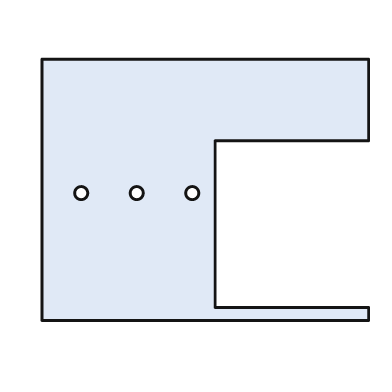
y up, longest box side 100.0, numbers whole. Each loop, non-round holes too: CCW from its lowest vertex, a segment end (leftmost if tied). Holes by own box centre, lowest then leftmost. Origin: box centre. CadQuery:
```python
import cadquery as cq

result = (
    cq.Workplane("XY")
    .moveTo(-50.0, -40.0)
    .lineTo(50.0, -40.0)
    .lineTo(50.0, -36.0)
    .lineTo(3.0, -36.0)
    .lineTo(3.0, 15.0)
    .lineTo(50.0, 15.0)
    .lineTo(50.0, 40.0)
    .lineTo(-50.0, 40.0)
    .close()
    .moveTo(-38.0, -1.0)
    .circle(2.0)
    .moveTo(-21.0, -1.0)
    .circle(2.0)
    .moveTo(-4.0, -1.0)
    .circle(2.0)
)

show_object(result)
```